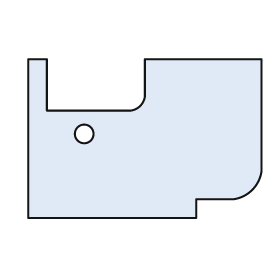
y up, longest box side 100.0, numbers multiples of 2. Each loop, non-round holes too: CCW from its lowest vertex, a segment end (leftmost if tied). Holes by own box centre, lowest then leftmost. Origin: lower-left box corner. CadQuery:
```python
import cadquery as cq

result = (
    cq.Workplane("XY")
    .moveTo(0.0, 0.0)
    .lineTo(72.0, 0.0)
    .lineTo(72.0, 8.0)
    .lineTo(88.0, 8.0)
    .threePointArc((96.0, 12.0), (100.0, 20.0))
    .lineTo(100.0, 68.0)
    .lineTo(50.0, 68.0)
    .lineTo(50.0, 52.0)
    .threePointArc((48.0, 48.0), (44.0, 46.0))
    .lineTo(8.0, 46.0)
    .lineTo(8.0, 68.0)
    .lineTo(0.0, 68.0)
    .close()
    .moveTo(24.0, 36.0)
    .circle(4.0)
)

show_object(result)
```